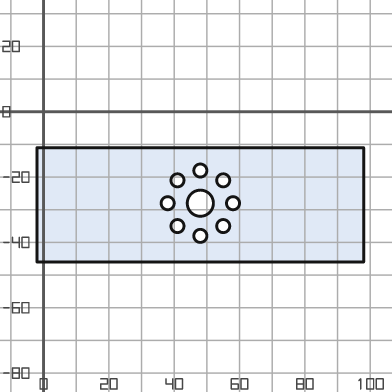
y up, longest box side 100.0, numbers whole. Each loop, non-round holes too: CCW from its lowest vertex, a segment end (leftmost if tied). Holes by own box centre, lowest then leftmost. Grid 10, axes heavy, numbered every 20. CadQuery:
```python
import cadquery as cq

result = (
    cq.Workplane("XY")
    .moveTo(-2.0, -46.0)
    .lineTo(98.0, -46.0)
    .lineTo(98.0, -11.0)
    .lineTo(-2.0, -11.0)
    .close()
    .moveTo(48.0, -38.0)
    .circle(2.0)
    .moveTo(41.0, -35.0)
    .circle(2.0)
    .moveTo(55.0, -35.0)
    .circle(2.0)
    .moveTo(38.0, -28.0)
    .circle(2.0)
    .moveTo(48.0, -28.0)
    .circle(4.0)
    .moveTo(58.0, -28.0)
    .circle(2.0)
    .moveTo(41.0, -21.0)
    .circle(2.0)
    .moveTo(55.0, -21.0)
    .circle(2.0)
    .moveTo(48.0, -18.0)
    .circle(2.0)
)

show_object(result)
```